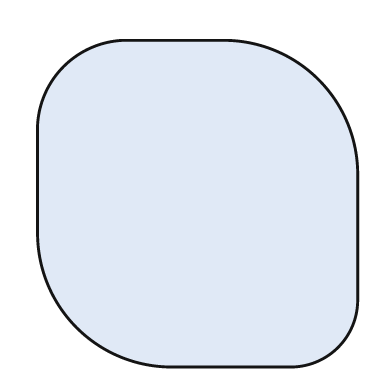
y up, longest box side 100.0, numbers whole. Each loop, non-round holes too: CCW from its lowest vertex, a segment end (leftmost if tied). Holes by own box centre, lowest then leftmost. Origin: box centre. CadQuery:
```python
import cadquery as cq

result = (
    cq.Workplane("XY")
    .moveTo(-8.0, -50.0)
    .lineTo(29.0, -50.0)
    .threePointArc((43.0, -44.0), (49.0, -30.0))
    .lineTo(49.0, 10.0)
    .threePointArc((37.0, 38.0), (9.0, 50.0))
    .lineTo(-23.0, 50.0)
    .threePointArc((-41.0, 42.0), (-49.0, 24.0))
    .lineTo(-49.0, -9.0)
    .threePointArc((-37.0, -38.0), (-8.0, -50.0))
    .close()
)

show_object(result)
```